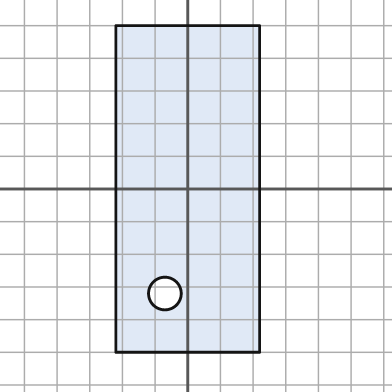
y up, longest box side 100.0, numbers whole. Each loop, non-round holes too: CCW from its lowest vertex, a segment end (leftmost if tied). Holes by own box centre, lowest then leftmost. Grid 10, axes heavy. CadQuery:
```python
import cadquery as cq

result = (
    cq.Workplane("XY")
    .moveTo(-22.0, -50.0)
    .lineTo(22.0, -50.0)
    .lineTo(22.0, 50.0)
    .lineTo(-22.0, 50.0)
    .close()
    .moveTo(-7.0, -32.0)
    .circle(5.0)
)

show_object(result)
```